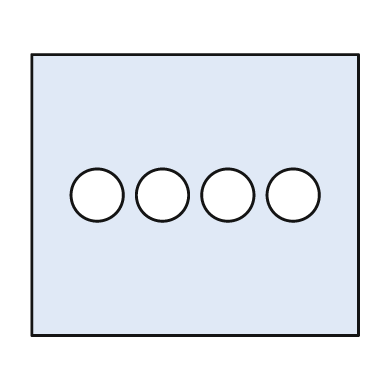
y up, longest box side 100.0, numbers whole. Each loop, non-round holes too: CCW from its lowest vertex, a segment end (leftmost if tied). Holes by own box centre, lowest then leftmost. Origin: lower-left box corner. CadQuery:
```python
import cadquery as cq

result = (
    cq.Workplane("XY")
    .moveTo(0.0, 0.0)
    .lineTo(100.0, 0.0)
    .lineTo(100.0, 86.0)
    .lineTo(0.0, 86.0)
    .close()
    .moveTo(20.0, 43.0)
    .circle(8.0)
    .moveTo(40.0, 43.0)
    .circle(8.0)
    .moveTo(60.0, 43.0)
    .circle(8.0)
    .moveTo(80.0, 43.0)
    .circle(8.0)
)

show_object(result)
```